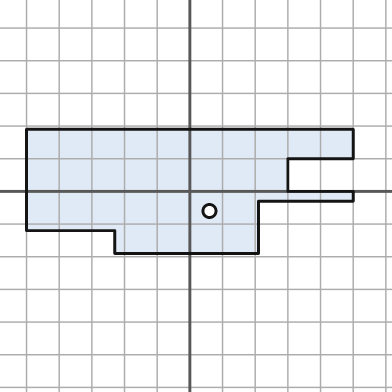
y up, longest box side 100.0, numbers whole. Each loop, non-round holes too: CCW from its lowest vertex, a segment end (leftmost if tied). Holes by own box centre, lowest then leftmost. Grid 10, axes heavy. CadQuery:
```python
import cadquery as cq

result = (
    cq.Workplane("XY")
    .moveTo(-23.0, -19.0)
    .lineTo(21.0, -19.0)
    .lineTo(21.0, -3.0)
    .lineTo(50.0, -3.0)
    .lineTo(50.0, 0.0)
    .lineTo(30.0, 0.0)
    .lineTo(30.0, 10.0)
    .lineTo(50.0, 10.0)
    .lineTo(50.0, 19.0)
    .lineTo(-50.0, 19.0)
    .lineTo(-50.0, -12.0)
    .lineTo(-23.0, -12.0)
    .close()
    .moveTo(6.0, -6.0)
    .circle(2.0)
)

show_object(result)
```